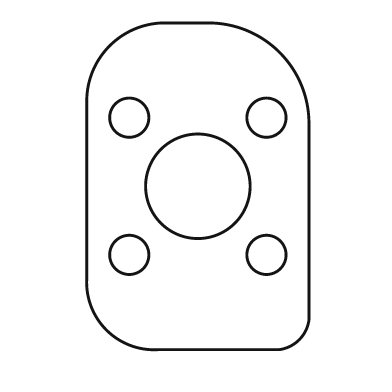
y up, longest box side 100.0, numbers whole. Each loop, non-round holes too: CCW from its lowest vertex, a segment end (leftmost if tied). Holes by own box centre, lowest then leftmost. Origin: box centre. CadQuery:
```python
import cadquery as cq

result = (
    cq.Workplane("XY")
    .moveTo(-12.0, -50.0)
    .lineTo(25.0, -50.0)
    .threePointArc((31.0, -47.0), (34.0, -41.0))
    .lineTo(34.0, 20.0)
    .threePointArc((25.0, 41.0), (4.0, 50.0))
    .lineTo(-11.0, 50.0)
    .threePointArc((-27.0, 43.0), (-34.0, 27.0))
    .lineTo(-34.0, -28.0)
    .threePointArc((-28.0, -44.0), (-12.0, -50.0))
    .close()
    .moveTo(-21.0, -21.0)
    .circle(6.0)
    .moveTo(21.0, -21.0)
    .circle(6.0)
    .moveTo(0.0, 0.0)
    .circle(16.0)
    .moveTo(-21.0, 21.0)
    .circle(6.0)
    .moveTo(21.0, 21.0)
    .circle(6.0)
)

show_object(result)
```